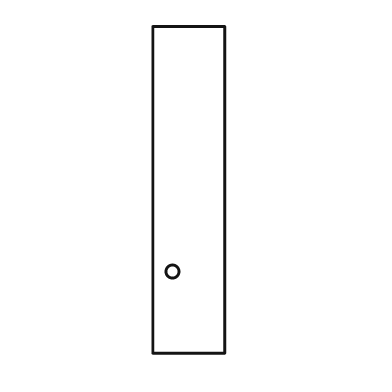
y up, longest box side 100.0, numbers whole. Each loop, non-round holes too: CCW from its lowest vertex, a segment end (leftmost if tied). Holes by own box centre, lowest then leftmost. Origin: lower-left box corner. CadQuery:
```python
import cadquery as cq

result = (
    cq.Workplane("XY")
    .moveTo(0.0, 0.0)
    .lineTo(22.0, 0.0)
    .lineTo(22.0, 100.0)
    .lineTo(0.0, 100.0)
    .close()
    .moveTo(6.0, 25.0)
    .circle(2.0)
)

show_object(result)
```